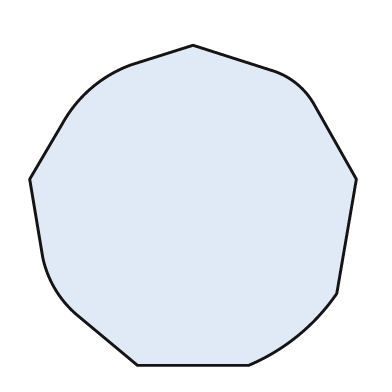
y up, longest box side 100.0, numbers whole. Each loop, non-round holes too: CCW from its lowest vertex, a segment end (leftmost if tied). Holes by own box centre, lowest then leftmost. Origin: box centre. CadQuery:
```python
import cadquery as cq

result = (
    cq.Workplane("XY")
    .moveTo(-17.0, -49.0)
    .lineTo(17.0, -49.0)
    .threePointArc((32.0, -40.0), (44.0, -27.0))
    .lineTo(50.0, 8.0)
    .lineTo(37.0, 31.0)
    .threePointArc((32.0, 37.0), (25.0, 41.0))
    .lineTo(0.0, 49.0)
    .lineTo(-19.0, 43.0)
    .threePointArc((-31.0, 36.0), (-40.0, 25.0))
    .lineTo(-50.0, 8.0)
    .lineTo(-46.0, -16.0)
    .threePointArc((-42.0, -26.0), (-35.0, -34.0))
    .close()
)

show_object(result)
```